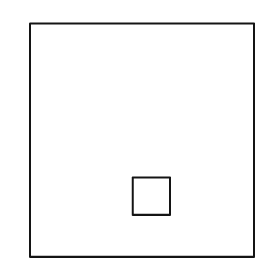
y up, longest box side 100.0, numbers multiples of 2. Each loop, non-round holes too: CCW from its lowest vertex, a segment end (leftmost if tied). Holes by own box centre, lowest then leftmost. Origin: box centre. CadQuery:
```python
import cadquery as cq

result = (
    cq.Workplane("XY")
    .moveTo(-48.0, -50.0)
    .lineTo(48.0, -50.0)
    .lineTo(48.0, 50.0)
    .lineTo(-48.0, 50.0)
    .close()
    .moveTo(-4.0, -32.0)
    .lineTo(12.0, -32.0)
    .lineTo(12.0, -16.0)
    .lineTo(-4.0, -16.0)
    .close()
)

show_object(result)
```